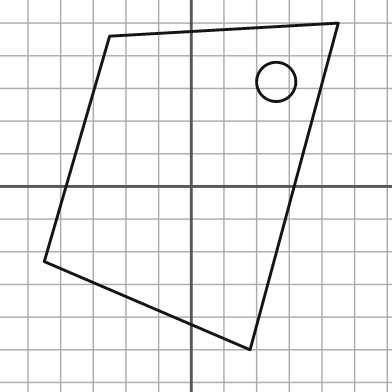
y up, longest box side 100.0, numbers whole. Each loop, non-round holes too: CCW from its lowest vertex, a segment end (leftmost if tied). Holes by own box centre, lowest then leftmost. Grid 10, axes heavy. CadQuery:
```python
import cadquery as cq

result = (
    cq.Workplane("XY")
    .moveTo(18.0, -50.0)
    .lineTo(45.0, 50.0)
    .lineTo(-25.0, 46.0)
    .lineTo(-45.0, -23.0)
    .close()
    .moveTo(26.0, 32.0)
    .circle(6.0)
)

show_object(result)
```